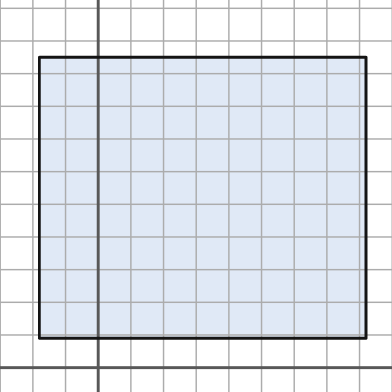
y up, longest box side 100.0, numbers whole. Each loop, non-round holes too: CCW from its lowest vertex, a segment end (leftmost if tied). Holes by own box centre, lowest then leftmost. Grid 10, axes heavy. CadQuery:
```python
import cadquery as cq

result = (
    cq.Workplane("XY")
    .moveTo(-18.0, 9.0)
    .lineTo(82.0, 9.0)
    .lineTo(82.0, 95.0)
    .lineTo(-18.0, 95.0)
    .close()
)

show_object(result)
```